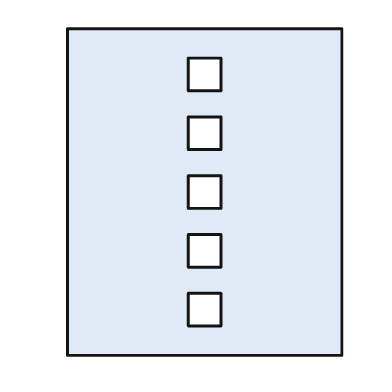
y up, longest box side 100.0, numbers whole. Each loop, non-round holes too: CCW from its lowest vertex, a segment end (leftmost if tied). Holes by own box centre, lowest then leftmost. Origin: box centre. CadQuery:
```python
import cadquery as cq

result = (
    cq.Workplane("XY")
    .moveTo(-42.0, -50.0)
    .lineTo(42.0, -50.0)
    .lineTo(42.0, 50.0)
    .lineTo(-42.0, 50.0)
    .close()
    .moveTo(-5.0, -41.0)
    .lineTo(5.0, -41.0)
    .lineTo(5.0, -31.0)
    .lineTo(-5.0, -31.0)
    .close()
    .moveTo(-5.0, -23.0)
    .lineTo(5.0, -23.0)
    .lineTo(5.0, -13.0)
    .lineTo(-5.0, -13.0)
    .close()
    .moveTo(-5.0, -5.0)
    .lineTo(5.0, -5.0)
    .lineTo(5.0, 5.0)
    .lineTo(-5.0, 5.0)
    .close()
    .moveTo(-5.0, 13.0)
    .lineTo(5.0, 13.0)
    .lineTo(5.0, 23.0)
    .lineTo(-5.0, 23.0)
    .close()
    .moveTo(-5.0, 31.0)
    .lineTo(5.0, 31.0)
    .lineTo(5.0, 41.0)
    .lineTo(-5.0, 41.0)
    .close()
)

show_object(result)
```